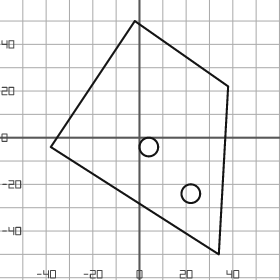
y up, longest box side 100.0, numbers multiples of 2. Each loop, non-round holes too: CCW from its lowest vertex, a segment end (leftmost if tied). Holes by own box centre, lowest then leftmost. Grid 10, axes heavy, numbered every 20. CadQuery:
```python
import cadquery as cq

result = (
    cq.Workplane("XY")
    .moveTo(34.0, -50.0)
    .lineTo(38.0, 22.0)
    .lineTo(-2.0, 50.0)
    .lineTo(-38.0, -4.0)
    .close()
    .moveTo(22.0, -24.0)
    .circle(4.0)
    .moveTo(4.0, -4.0)
    .circle(4.0)
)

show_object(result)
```